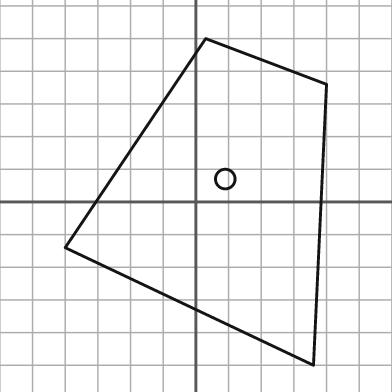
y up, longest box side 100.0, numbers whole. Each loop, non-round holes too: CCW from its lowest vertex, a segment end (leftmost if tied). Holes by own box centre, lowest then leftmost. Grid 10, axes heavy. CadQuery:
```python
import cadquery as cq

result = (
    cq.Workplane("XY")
    .moveTo(36.0, -50.0)
    .lineTo(40.0, 36.0)
    .lineTo(3.0, 50.0)
    .lineTo(-40.0, -14.0)
    .close()
    .moveTo(9.0, 7.0)
    .circle(3.0)
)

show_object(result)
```